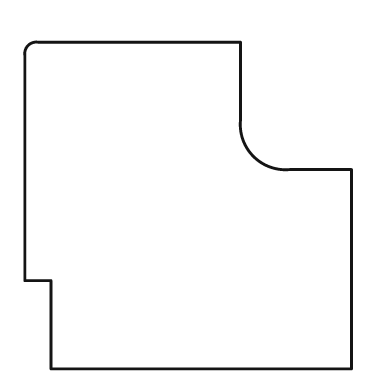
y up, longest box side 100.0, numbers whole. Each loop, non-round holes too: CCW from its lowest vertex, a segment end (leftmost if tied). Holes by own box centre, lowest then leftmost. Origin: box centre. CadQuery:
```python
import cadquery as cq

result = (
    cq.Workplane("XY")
    .moveTo(-42.0, -50.0)
    .lineTo(50.0, -50.0)
    .lineTo(50.0, 11.0)
    .lineTo(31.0, 11.0)
    .threePointArc((20.0, 15.0), (16.0, 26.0))
    .lineTo(16.0, 50.0)
    .lineTo(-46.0, 50.0)
    .threePointArc((-49.0, 49.0), (-50.0, 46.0))
    .lineTo(-50.0, -23.0)
    .lineTo(-42.0, -23.0)
    .close()
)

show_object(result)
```